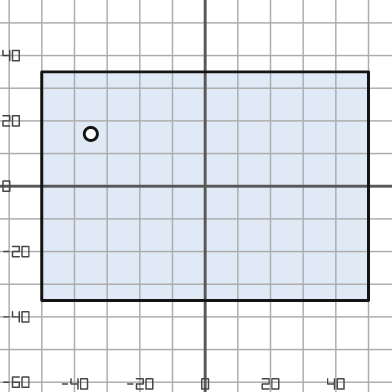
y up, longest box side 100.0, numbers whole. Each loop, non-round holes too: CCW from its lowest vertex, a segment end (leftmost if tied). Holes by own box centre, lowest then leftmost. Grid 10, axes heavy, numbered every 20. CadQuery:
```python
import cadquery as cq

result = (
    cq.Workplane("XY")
    .moveTo(-50.0, -35.0)
    .lineTo(50.0, -35.0)
    .lineTo(50.0, 35.0)
    .lineTo(-50.0, 35.0)
    .close()
    .moveTo(-35.0, 16.0)
    .circle(2.0)
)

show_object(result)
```